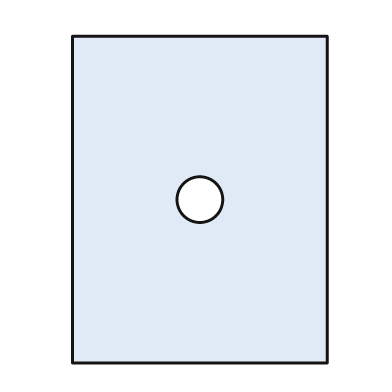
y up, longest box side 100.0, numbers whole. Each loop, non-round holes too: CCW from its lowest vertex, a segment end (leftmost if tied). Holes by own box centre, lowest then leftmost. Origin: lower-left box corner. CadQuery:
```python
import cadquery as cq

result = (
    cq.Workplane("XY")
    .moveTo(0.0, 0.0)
    .lineTo(78.0, 0.0)
    .lineTo(78.0, 100.0)
    .lineTo(0.0, 100.0)
    .close()
    .moveTo(39.0, 50.0)
    .circle(7.0)
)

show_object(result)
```